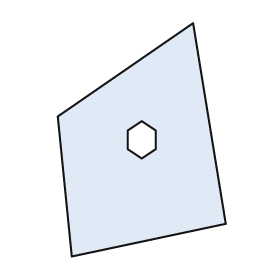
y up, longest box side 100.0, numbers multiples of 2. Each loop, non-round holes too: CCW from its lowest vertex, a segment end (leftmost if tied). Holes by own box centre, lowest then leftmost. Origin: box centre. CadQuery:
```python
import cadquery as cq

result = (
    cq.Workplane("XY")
    .moveTo(-30.0, -50.0)
    .lineTo(36.0, -36.0)
    .lineTo(22.0, 50.0)
    .lineTo(-36.0, 10.0)
    .close()
    .moveTo(0.0, -8.0)
    .lineTo(6.0, -4.0)
    .lineTo(6.0, 4.0)
    .lineTo(0.0, 8.0)
    .lineTo(-6.0, 4.0)
    .lineTo(-6.0, -4.0)
    .close()
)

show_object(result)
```